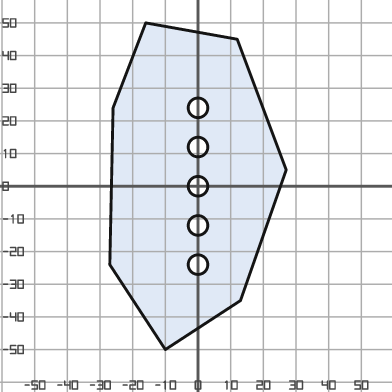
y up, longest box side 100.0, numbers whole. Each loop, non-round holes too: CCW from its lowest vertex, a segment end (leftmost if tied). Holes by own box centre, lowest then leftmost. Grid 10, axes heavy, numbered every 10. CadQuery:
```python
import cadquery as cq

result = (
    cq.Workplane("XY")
    .moveTo(-10.0, -50.0)
    .lineTo(13.0, -35.0)
    .lineTo(27.0, 5.0)
    .lineTo(12.0, 45.0)
    .lineTo(-16.0, 50.0)
    .lineTo(-26.0, 24.0)
    .lineTo(-27.0, -24.0)
    .close()
    .moveTo(0.0, -24.0)
    .circle(3.0)
    .moveTo(0.0, -12.0)
    .circle(3.0)
    .moveTo(0.0, 0.0)
    .circle(3.0)
    .moveTo(0.0, 12.0)
    .circle(3.0)
    .moveTo(0.0, 24.0)
    .circle(3.0)
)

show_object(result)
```